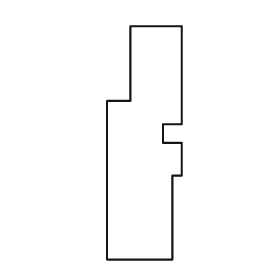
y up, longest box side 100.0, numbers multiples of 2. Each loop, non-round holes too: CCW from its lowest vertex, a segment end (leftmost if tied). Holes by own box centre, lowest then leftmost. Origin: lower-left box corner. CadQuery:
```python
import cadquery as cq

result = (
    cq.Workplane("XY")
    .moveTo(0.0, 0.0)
    .lineTo(28.0, 0.0)
    .lineTo(28.0, 36.0)
    .lineTo(32.0, 36.0)
    .lineTo(32.0, 50.0)
    .lineTo(24.0, 50.0)
    .lineTo(24.0, 58.0)
    .lineTo(32.0, 58.0)
    .lineTo(32.0, 100.0)
    .lineTo(10.0, 100.0)
    .lineTo(10.0, 68.0)
    .lineTo(0.0, 68.0)
    .close()
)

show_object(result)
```